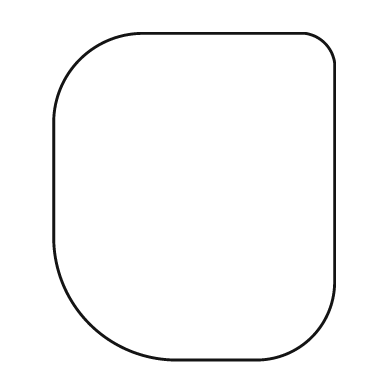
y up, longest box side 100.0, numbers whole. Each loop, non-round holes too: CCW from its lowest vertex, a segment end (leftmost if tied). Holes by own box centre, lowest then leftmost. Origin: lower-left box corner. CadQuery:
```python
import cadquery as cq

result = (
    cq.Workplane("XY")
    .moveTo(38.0, 0.0)
    .lineTo(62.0, 0.0)
    .threePointArc((79.0, 7.0), (86.0, 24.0))
    .lineTo(86.0, 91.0)
    .threePointArc((83.0, 97.0), (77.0, 100.0))
    .lineTo(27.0, 100.0)
    .threePointArc((8.0, 92.0), (0.0, 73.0))
    .lineTo(0.0, 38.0)
    .threePointArc((11.0, 11.0), (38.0, 0.0))
    .close()
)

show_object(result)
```